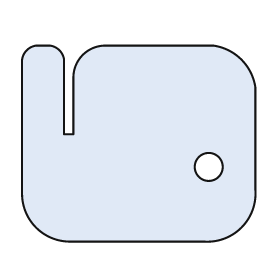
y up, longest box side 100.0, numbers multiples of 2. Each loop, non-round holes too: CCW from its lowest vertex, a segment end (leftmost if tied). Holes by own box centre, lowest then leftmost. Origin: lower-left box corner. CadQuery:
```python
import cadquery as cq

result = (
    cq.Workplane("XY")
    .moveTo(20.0, 0.0)
    .lineTo(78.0, 0.0)
    .threePointArc((94.0, 6.0), (100.0, 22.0))
    .lineTo(100.0, 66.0)
    .threePointArc((94.0, 78.0), (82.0, 84.0))
    .lineTo(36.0, 84.0)
    .threePointArc((26.0, 80.0), (22.0, 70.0))
    .lineTo(22.0, 46.0)
    .lineTo(18.0, 46.0)
    .lineTo(18.0, 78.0)
    .threePointArc((16.0, 82.0), (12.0, 84.0))
    .lineTo(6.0, 84.0)
    .threePointArc((2.0, 82.0), (0.0, 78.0))
    .lineTo(0.0, 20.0)
    .threePointArc((6.0, 6.0), (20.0, 0.0))
    .close()
    .moveTo(80.0, 32.0)
    .circle(6.0)
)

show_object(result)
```